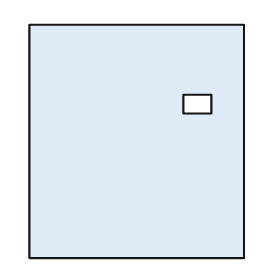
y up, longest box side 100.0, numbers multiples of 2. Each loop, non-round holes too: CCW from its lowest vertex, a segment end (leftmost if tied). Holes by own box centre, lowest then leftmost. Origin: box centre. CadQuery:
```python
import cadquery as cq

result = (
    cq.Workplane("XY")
    .moveTo(-46.0, -50.0)
    .lineTo(46.0, -50.0)
    .lineTo(46.0, 50.0)
    .lineTo(-46.0, 50.0)
    .close()
    .moveTo(20.0, 12.0)
    .lineTo(32.0, 12.0)
    .lineTo(32.0, 20.0)
    .lineTo(20.0, 20.0)
    .close()
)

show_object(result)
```